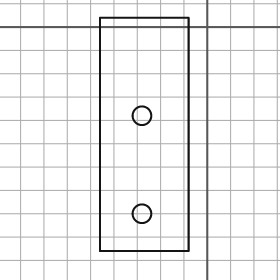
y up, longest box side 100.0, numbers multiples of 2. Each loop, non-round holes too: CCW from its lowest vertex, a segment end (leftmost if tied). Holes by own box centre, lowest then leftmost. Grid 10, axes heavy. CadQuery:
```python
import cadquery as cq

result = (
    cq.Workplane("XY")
    .moveTo(-46.0, -96.0)
    .lineTo(-8.0, -96.0)
    .lineTo(-8.0, 4.0)
    .lineTo(-46.0, 4.0)
    .close()
    .moveTo(-28.0, -80.0)
    .circle(4.0)
    .moveTo(-28.0, -38.0)
    .circle(4.0)
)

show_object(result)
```